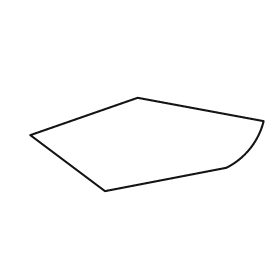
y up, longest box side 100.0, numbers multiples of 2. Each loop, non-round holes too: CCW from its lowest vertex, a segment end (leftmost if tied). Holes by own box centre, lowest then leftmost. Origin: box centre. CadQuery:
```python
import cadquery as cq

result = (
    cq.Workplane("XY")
    .moveTo(-18.0, -20.0)
    .lineTo(34.0, -10.0)
    .threePointArc((44.0, -2.0), (50.0, 10.0))
    .lineTo(-4.0, 20.0)
    .lineTo(-50.0, 4.0)
    .close()
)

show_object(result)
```